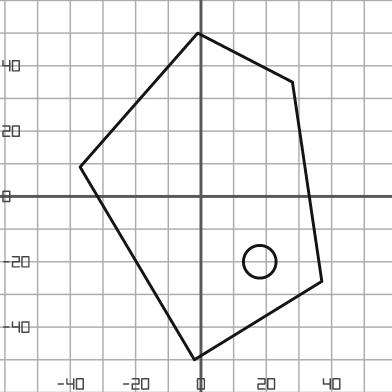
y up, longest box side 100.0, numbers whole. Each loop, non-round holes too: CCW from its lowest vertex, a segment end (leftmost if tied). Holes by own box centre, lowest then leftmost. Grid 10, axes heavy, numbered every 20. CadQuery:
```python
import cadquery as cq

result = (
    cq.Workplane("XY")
    .moveTo(-2.0, -50.0)
    .lineTo(37.0, -26.0)
    .lineTo(28.0, 35.0)
    .lineTo(-1.0, 50.0)
    .lineTo(-37.0, 9.0)
    .close()
    .moveTo(18.0, -20.0)
    .circle(5.0)
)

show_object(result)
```